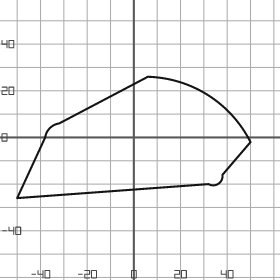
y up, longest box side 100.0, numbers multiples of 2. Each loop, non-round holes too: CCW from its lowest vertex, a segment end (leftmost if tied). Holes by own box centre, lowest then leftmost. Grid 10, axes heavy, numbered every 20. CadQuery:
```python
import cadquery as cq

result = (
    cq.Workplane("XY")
    .moveTo(-50.0, -26.0)
    .lineTo(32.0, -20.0)
    .threePointArc((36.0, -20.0), (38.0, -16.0))
    .lineTo(50.0, -2.0)
    .threePointArc((32.0, 18.0), (6.0, 26.0))
    .lineTo(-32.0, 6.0)
    .threePointArc((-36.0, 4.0), (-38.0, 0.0))
    .close()
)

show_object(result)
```